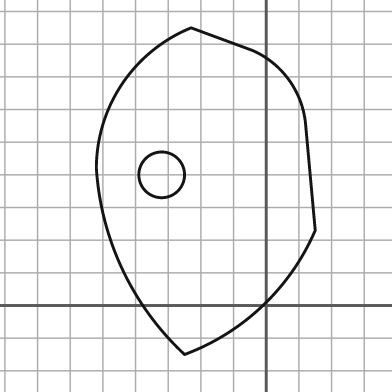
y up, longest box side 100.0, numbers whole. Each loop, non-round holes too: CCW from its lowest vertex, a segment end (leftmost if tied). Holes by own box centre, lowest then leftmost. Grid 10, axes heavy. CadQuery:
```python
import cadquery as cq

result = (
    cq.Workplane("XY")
    .moveTo(-25.0, -15.0)
    .threePointArc((-1.0, 0.0), (15.0, 23.0))
    .lineTo(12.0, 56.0)
    .threePointArc((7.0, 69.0), (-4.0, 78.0))
    .lineTo(-23.0, 85.0)
    .threePointArc((-44.0, 68.0), (-52.0, 42.0))
    .threePointArc((-44.0, 11.0), (-25.0, -15.0))
    .close()
    .moveTo(-32.0, 40.0)
    .circle(7.0)
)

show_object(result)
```